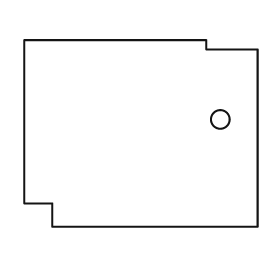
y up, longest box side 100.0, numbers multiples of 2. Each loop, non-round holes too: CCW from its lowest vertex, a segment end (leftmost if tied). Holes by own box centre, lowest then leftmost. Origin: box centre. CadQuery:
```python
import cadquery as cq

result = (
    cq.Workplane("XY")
    .moveTo(-38.0, -40.0)
    .lineTo(50.0, -40.0)
    .lineTo(50.0, 36.0)
    .lineTo(28.0, 36.0)
    .lineTo(28.0, 40.0)
    .lineTo(-50.0, 40.0)
    .lineTo(-50.0, -30.0)
    .lineTo(-38.0, -30.0)
    .close()
    .moveTo(34.0, 6.0)
    .circle(4.0)
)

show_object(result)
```